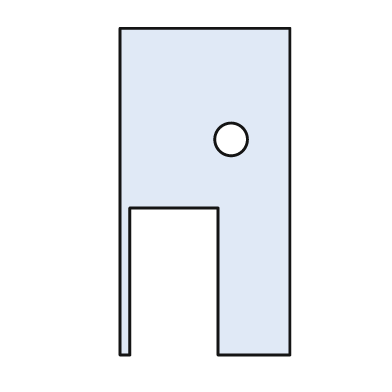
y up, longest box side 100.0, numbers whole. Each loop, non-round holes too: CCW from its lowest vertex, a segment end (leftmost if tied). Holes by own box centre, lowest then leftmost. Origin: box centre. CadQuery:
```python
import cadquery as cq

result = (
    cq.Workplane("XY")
    .moveTo(-26.0, -50.0)
    .lineTo(-23.0, -50.0)
    .lineTo(-23.0, -5.0)
    .lineTo(4.0, -5.0)
    .lineTo(4.0, -50.0)
    .lineTo(26.0, -50.0)
    .lineTo(26.0, 50.0)
    .lineTo(-26.0, 50.0)
    .close()
    .moveTo(8.0, 16.0)
    .circle(5.0)
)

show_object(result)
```